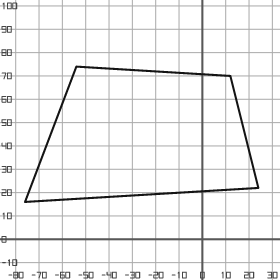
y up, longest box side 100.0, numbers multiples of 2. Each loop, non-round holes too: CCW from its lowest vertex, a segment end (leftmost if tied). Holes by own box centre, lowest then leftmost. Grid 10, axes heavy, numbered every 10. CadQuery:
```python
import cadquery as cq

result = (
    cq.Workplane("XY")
    .moveTo(-76.0, 16.0)
    .lineTo(24.0, 22.0)
    .lineTo(12.0, 70.0)
    .lineTo(-54.0, 74.0)
    .close()
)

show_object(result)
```